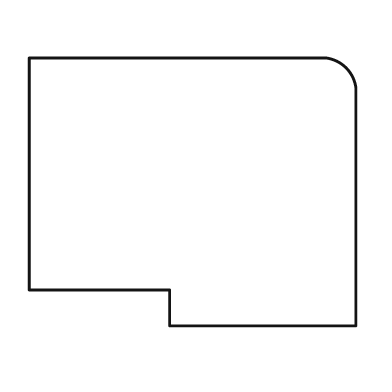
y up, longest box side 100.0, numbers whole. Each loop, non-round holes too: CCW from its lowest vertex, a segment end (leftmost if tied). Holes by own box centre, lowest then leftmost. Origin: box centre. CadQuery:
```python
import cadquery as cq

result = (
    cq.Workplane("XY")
    .moveTo(-7.0, -41.0)
    .lineTo(50.0, -41.0)
    .lineTo(50.0, 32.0)
    .threePointArc((47.0, 38.0), (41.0, 41.0))
    .lineTo(-50.0, 41.0)
    .lineTo(-50.0, -30.0)
    .lineTo(-7.0, -30.0)
    .close()
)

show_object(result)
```